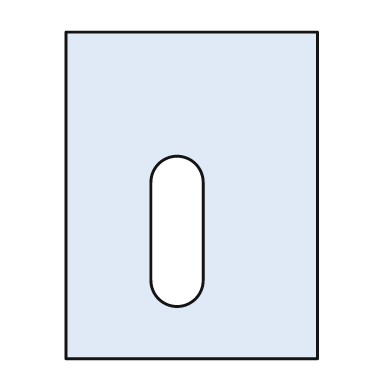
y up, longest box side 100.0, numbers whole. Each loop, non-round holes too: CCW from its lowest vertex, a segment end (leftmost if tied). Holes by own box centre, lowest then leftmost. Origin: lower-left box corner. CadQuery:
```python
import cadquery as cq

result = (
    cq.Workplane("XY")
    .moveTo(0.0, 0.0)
    .lineTo(77.0, 0.0)
    .lineTo(77.0, 100.0)
    .lineTo(0.0, 100.0)
    .close()
    .moveTo(26.0, 24.0)
    .threePointArc((34.0, 16.0), (42.0, 24.0))
    .lineTo(42.0, 54.0)
    .threePointArc((34.0, 62.0), (26.0, 54.0))
    .close()
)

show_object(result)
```